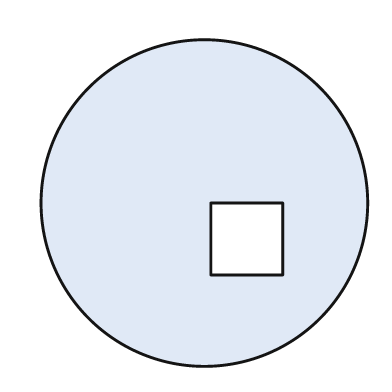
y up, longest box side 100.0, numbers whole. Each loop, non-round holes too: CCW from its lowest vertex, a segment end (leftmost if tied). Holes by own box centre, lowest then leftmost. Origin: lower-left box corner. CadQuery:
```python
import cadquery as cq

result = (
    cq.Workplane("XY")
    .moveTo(50.0, 50.0)
    .circle(50.0)
    .moveTo(52.0, 28.0)
    .lineTo(74.0, 28.0)
    .lineTo(74.0, 50.0)
    .lineTo(52.0, 50.0)
    .close()
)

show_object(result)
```